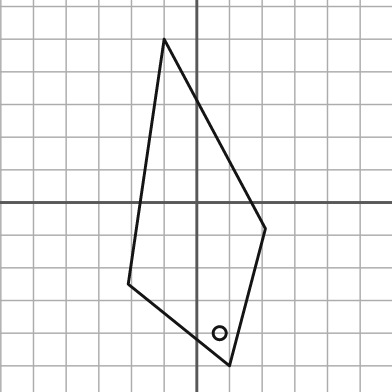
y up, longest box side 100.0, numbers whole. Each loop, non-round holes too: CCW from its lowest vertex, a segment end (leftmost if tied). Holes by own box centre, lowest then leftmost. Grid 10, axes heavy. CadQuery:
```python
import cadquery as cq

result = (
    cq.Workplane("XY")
    .moveTo(10.0, -50.0)
    .lineTo(21.0, -8.0)
    .lineTo(-10.0, 50.0)
    .lineTo(-21.0, -25.0)
    .close()
    .moveTo(7.0, -40.0)
    .circle(2.0)
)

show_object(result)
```